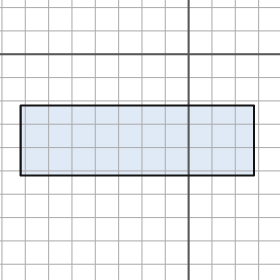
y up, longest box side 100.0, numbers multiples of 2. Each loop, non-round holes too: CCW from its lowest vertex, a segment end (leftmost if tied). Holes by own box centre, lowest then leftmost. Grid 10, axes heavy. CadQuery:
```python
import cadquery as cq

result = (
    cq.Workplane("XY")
    .moveTo(-72.0, -52.0)
    .lineTo(28.0, -52.0)
    .lineTo(28.0, -22.0)
    .lineTo(-72.0, -22.0)
    .close()
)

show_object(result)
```